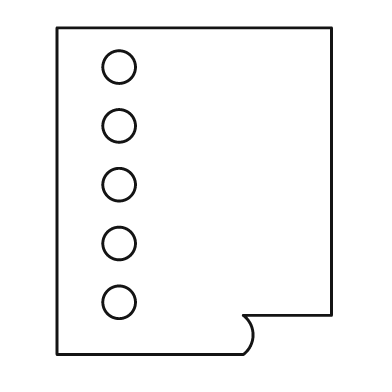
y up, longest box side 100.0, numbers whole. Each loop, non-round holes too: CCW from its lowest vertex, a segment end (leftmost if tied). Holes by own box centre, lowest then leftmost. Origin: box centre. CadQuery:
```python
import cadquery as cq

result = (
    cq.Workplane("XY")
    .moveTo(-42.0, -50.0)
    .lineTo(15.0, -50.0)
    .threePointArc((18.0, -44.0), (15.0, -38.0))
    .lineTo(42.0, -38.0)
    .lineTo(42.0, 50.0)
    .lineTo(-42.0, 50.0)
    .close()
    .moveTo(-23.0, -34.0)
    .circle(5.0)
    .moveTo(-23.0, -16.0)
    .circle(5.0)
    .moveTo(-23.0, 2.0)
    .circle(5.0)
    .moveTo(-23.0, 20.0)
    .circle(5.0)
    .moveTo(-23.0, 38.0)
    .circle(5.0)
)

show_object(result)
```